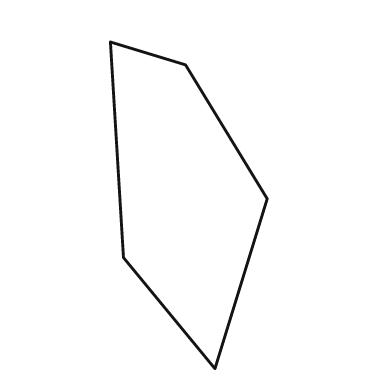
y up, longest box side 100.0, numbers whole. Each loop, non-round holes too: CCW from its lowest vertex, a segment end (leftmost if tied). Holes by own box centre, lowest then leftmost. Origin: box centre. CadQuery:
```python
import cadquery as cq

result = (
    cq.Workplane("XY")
    .moveTo(8.0, -50.0)
    .lineTo(24.0, 2.0)
    .lineTo(-1.0, 43.0)
    .lineTo(-24.0, 50.0)
    .lineTo(-20.0, -16.0)
    .close()
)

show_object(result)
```